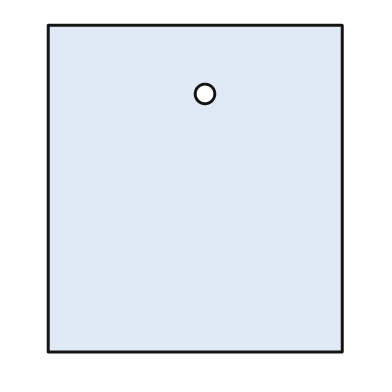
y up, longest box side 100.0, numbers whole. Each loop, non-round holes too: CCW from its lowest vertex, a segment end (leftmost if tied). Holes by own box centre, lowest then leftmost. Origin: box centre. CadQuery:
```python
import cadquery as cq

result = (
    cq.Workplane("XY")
    .moveTo(-45.0, -50.0)
    .lineTo(45.0, -50.0)
    .lineTo(45.0, 50.0)
    .lineTo(-45.0, 50.0)
    .close()
    .moveTo(3.0, 29.0)
    .circle(3.0)
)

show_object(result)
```